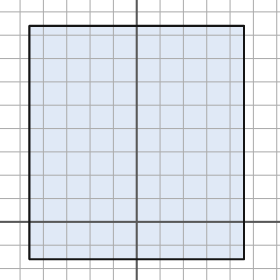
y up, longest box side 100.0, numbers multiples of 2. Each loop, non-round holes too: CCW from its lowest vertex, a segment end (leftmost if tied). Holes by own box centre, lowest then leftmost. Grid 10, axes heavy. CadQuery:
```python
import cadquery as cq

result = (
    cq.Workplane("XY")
    .moveTo(-46.0, -16.0)
    .lineTo(46.0, -16.0)
    .lineTo(46.0, 84.0)
    .lineTo(-46.0, 84.0)
    .close()
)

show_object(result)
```